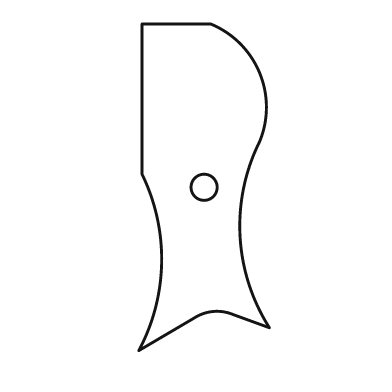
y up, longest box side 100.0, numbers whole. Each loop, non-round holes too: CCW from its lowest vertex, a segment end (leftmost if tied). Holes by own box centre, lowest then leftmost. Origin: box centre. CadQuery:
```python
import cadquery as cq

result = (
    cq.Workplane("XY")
    .moveTo(-20.0, -50.0)
    .lineTo(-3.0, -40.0)
    .threePointArc((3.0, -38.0), (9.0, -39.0))
    .lineTo(20.0, -43.0)
    .threePointArc((11.0, -15.0), (17.0, 14.0))
    .threePointArc((17.0, 35.0), (2.0, 50.0))
    .lineTo(-19.0, 50.0)
    .lineTo(-19.0, 4.0)
    .threePointArc((-13.0, -23.0), (-20.0, -50.0))
    .close()
    .moveTo(0.0, 0.0)
    .circle(4.0)
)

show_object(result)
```